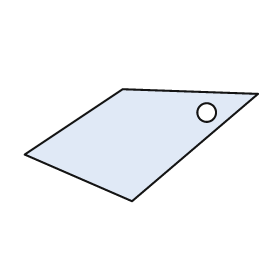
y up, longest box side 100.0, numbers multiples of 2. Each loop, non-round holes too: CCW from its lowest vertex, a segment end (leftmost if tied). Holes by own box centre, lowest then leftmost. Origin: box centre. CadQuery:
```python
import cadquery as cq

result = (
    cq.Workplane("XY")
    .moveTo(-4.0, -24.0)
    .lineTo(50.0, 22.0)
    .lineTo(-8.0, 24.0)
    .lineTo(-50.0, -4.0)
    .close()
    .moveTo(28.0, 14.0)
    .circle(4.0)
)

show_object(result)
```